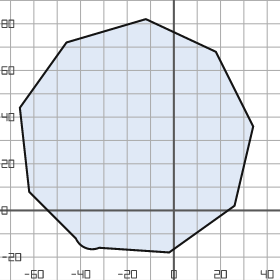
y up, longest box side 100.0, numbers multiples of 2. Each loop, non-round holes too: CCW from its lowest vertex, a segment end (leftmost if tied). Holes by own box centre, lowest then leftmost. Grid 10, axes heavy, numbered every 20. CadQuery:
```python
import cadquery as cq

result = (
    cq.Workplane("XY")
    .moveTo(-2.0, -18.0)
    .lineTo(26.0, 2.0)
    .lineTo(34.0, 36.0)
    .lineTo(18.0, 68.0)
    .lineTo(-12.0, 82.0)
    .lineTo(-46.0, 72.0)
    .lineTo(-66.0, 44.0)
    .lineTo(-62.0, 8.0)
    .lineTo(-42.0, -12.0)
    .threePointArc((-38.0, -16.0), (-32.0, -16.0))
    .close()
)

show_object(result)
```